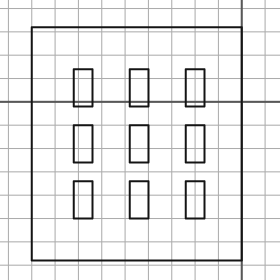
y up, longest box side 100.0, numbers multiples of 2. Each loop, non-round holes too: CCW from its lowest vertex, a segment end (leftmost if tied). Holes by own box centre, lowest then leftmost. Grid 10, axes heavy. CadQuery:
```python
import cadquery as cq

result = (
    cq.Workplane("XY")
    .moveTo(-90.0, -68.0)
    .lineTo(0.0, -68.0)
    .lineTo(0.0, 32.0)
    .lineTo(-90.0, 32.0)
    .close()
    .moveTo(-72.0, -50.0)
    .lineTo(-64.0, -50.0)
    .lineTo(-64.0, -34.0)
    .lineTo(-72.0, -34.0)
    .close()
    .moveTo(-48.0, -50.0)
    .lineTo(-40.0, -50.0)
    .lineTo(-40.0, -34.0)
    .lineTo(-48.0, -34.0)
    .close()
    .moveTo(-24.0, -50.0)
    .lineTo(-16.0, -50.0)
    .lineTo(-16.0, -34.0)
    .lineTo(-24.0, -34.0)
    .close()
    .moveTo(-72.0, -26.0)
    .lineTo(-64.0, -26.0)
    .lineTo(-64.0, -10.0)
    .lineTo(-72.0, -10.0)
    .close()
    .moveTo(-48.0, -26.0)
    .lineTo(-40.0, -26.0)
    .lineTo(-40.0, -10.0)
    .lineTo(-48.0, -10.0)
    .close()
    .moveTo(-24.0, -26.0)
    .lineTo(-16.0, -26.0)
    .lineTo(-16.0, -10.0)
    .lineTo(-24.0, -10.0)
    .close()
    .moveTo(-72.0, -2.0)
    .lineTo(-64.0, -2.0)
    .lineTo(-64.0, 14.0)
    .lineTo(-72.0, 14.0)
    .close()
    .moveTo(-48.0, -2.0)
    .lineTo(-40.0, -2.0)
    .lineTo(-40.0, 14.0)
    .lineTo(-48.0, 14.0)
    .close()
    .moveTo(-24.0, -2.0)
    .lineTo(-16.0, -2.0)
    .lineTo(-16.0, 14.0)
    .lineTo(-24.0, 14.0)
    .close()
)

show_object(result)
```